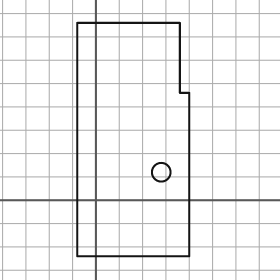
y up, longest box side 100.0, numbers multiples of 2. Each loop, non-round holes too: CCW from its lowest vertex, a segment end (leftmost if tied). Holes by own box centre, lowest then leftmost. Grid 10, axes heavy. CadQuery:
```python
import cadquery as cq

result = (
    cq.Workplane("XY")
    .moveTo(-8.0, -24.0)
    .lineTo(40.0, -24.0)
    .lineTo(40.0, 46.0)
    .lineTo(36.0, 46.0)
    .lineTo(36.0, 76.0)
    .lineTo(-8.0, 76.0)
    .close()
    .moveTo(28.0, 12.0)
    .circle(4.0)
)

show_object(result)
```